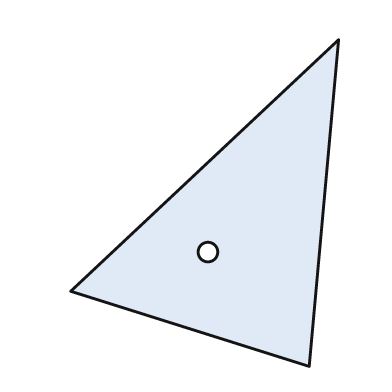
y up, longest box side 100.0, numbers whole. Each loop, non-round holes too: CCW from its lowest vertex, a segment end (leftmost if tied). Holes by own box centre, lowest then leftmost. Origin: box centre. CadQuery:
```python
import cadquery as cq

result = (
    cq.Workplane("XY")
    .moveTo(32.0, -50.0)
    .lineTo(41.0, 50.0)
    .lineTo(-41.0, -27.0)
    .close()
    .moveTo(1.0, -15.0)
    .circle(3.0)
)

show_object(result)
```